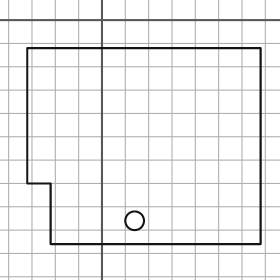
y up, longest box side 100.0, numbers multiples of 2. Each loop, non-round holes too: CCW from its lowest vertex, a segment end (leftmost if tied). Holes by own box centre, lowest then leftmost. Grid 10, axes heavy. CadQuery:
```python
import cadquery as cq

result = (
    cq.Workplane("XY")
    .moveTo(-22.0, -96.0)
    .lineTo(68.0, -96.0)
    .lineTo(68.0, -12.0)
    .lineTo(-32.0, -12.0)
    .lineTo(-32.0, -70.0)
    .lineTo(-22.0, -70.0)
    .close()
    .moveTo(14.0, -86.0)
    .circle(4.0)
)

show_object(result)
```